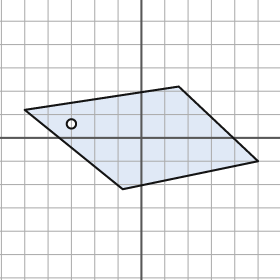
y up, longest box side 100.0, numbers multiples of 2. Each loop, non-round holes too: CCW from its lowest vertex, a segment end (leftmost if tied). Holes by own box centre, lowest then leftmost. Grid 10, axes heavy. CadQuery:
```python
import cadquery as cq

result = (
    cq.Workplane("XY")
    .moveTo(-8.0, -22.0)
    .lineTo(50.0, -10.0)
    .lineTo(16.0, 22.0)
    .lineTo(-50.0, 12.0)
    .close()
    .moveTo(-30.0, 6.0)
    .circle(2.0)
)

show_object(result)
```